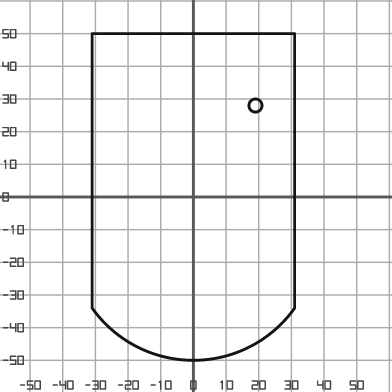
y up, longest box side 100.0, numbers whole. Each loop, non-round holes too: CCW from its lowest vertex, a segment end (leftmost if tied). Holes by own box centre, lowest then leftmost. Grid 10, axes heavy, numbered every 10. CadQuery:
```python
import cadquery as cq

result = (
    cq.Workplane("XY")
    .moveTo(-31.0, -34.0)
    .threePointArc((0.0, -50.0), (31.0, -34.0))
    .lineTo(31.0, 50.0)
    .lineTo(-31.0, 50.0)
    .close()
    .moveTo(19.0, 28.0)
    .circle(2.0)
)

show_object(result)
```